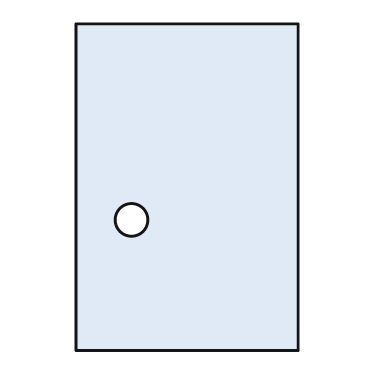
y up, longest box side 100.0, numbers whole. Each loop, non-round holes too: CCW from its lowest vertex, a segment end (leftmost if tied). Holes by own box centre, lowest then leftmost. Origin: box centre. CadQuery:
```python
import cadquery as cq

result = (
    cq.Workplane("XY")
    .moveTo(-34.0, -50.0)
    .lineTo(34.0, -50.0)
    .lineTo(34.0, 50.0)
    .lineTo(-34.0, 50.0)
    .close()
    .moveTo(-17.0, -10.0)
    .circle(5.0)
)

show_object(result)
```